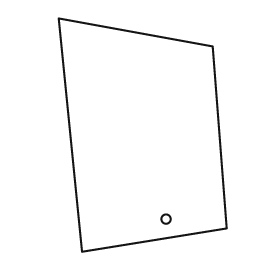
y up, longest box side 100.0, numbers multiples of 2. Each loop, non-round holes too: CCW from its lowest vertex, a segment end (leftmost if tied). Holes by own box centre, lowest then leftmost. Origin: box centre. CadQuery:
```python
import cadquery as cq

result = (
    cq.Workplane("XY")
    .moveTo(-26.0, -50.0)
    .lineTo(36.0, -40.0)
    .lineTo(30.0, 38.0)
    .lineTo(-36.0, 50.0)
    .close()
    .moveTo(10.0, -36.0)
    .circle(2.0)
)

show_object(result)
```